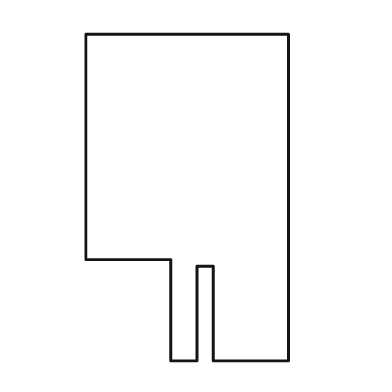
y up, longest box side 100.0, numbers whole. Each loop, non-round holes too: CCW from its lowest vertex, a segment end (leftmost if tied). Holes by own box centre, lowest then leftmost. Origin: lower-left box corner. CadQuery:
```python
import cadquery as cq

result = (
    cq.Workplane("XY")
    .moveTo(26.0, 0.0)
    .lineTo(34.0, 0.0)
    .lineTo(34.0, 29.0)
    .lineTo(39.0, 29.0)
    .lineTo(39.0, 0.0)
    .lineTo(62.0, 0.0)
    .lineTo(62.0, 100.0)
    .lineTo(0.0, 100.0)
    .lineTo(0.0, 31.0)
    .lineTo(26.0, 31.0)
    .close()
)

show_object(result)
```